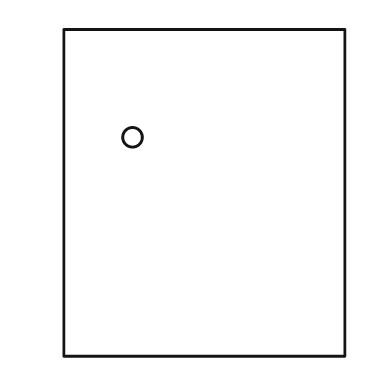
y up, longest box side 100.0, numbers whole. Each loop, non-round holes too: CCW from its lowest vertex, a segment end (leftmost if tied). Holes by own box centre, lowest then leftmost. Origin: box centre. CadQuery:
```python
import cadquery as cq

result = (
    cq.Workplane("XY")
    .moveTo(-43.0, -50.0)
    .lineTo(43.0, -50.0)
    .lineTo(43.0, 50.0)
    .lineTo(-43.0, 50.0)
    .close()
    .moveTo(-22.0, 17.0)
    .circle(3.0)
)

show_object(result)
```